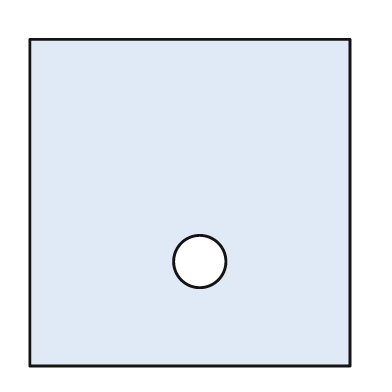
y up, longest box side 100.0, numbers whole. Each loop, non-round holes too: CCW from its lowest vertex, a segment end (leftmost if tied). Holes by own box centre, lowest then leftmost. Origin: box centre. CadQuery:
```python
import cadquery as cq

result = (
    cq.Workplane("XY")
    .moveTo(-49.0, -50.0)
    .lineTo(49.0, -50.0)
    .lineTo(49.0, 50.0)
    .lineTo(-49.0, 50.0)
    .close()
    .moveTo(3.0, -18.0)
    .circle(8.0)
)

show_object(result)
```